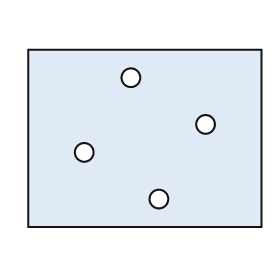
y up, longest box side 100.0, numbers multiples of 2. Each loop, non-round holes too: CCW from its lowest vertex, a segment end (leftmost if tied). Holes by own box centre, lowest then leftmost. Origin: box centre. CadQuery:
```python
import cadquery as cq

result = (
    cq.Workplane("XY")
    .moveTo(-50.0, -38.0)
    .lineTo(50.0, -38.0)
    .lineTo(50.0, 38.0)
    .lineTo(-50.0, 38.0)
    .close()
    .moveTo(6.0, -26.0)
    .circle(4.0)
    .moveTo(-26.0, -6.0)
    .circle(4.0)
    .moveTo(26.0, 6.0)
    .circle(4.0)
    .moveTo(-6.0, 26.0)
    .circle(4.0)
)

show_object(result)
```